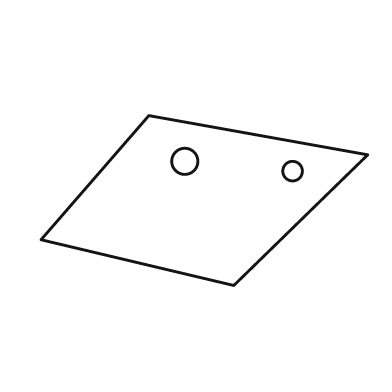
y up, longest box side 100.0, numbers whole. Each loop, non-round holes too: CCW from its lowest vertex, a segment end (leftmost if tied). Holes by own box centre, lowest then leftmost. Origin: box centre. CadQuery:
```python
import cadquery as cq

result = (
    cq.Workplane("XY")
    .moveTo(9.0, -26.0)
    .lineTo(50.0, 14.0)
    .lineTo(-17.0, 26.0)
    .lineTo(-50.0, -12.0)
    .close()
    .moveTo(27.0, 9.0)
    .circle(3.0)
    .moveTo(-6.0, 12.0)
    .circle(4.0)
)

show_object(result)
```